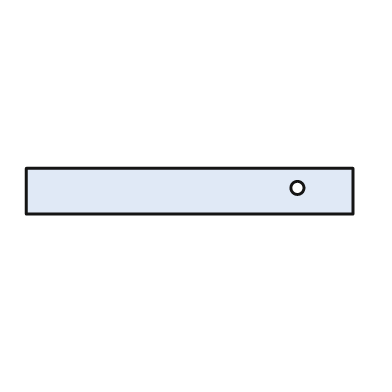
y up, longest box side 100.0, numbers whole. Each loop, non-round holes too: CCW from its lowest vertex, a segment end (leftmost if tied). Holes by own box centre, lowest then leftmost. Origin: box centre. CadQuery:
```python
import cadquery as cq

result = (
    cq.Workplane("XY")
    .moveTo(-50.0, -7.0)
    .lineTo(50.0, -7.0)
    .lineTo(50.0, 7.0)
    .lineTo(-50.0, 7.0)
    .close()
    .moveTo(33.0, 1.0)
    .circle(2.0)
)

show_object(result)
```